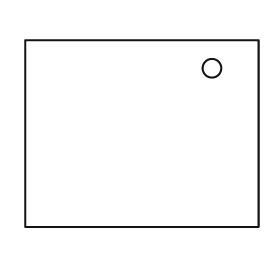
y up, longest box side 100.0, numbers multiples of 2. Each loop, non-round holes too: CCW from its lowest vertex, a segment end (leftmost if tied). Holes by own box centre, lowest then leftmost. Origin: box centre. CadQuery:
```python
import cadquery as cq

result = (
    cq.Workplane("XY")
    .moveTo(-50.0, -40.0)
    .lineTo(50.0, -40.0)
    .lineTo(50.0, 40.0)
    .lineTo(-50.0, 40.0)
    .close()
    .moveTo(30.0, 28.0)
    .circle(4.0)
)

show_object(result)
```